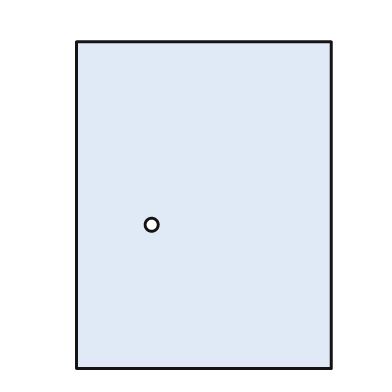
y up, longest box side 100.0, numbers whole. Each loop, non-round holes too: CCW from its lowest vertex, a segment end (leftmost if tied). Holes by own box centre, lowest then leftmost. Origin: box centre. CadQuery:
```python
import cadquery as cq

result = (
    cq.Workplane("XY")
    .moveTo(-39.0, -50.0)
    .lineTo(39.0, -50.0)
    .lineTo(39.0, 50.0)
    .lineTo(-39.0, 50.0)
    .close()
    .moveTo(-16.0, -6.0)
    .circle(2.0)
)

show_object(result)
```